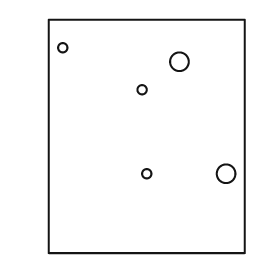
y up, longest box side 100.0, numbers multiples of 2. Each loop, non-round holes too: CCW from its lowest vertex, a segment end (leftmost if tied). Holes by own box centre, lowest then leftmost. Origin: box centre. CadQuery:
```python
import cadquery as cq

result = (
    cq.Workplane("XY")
    .moveTo(-42.0, -50.0)
    .lineTo(42.0, -50.0)
    .lineTo(42.0, 50.0)
    .lineTo(-42.0, 50.0)
    .close()
    .moveTo(0.0, -16.0)
    .circle(2.0)
    .moveTo(34.0, -16.0)
    .circle(4.0)
    .moveTo(-2.0, 20.0)
    .circle(2.0)
    .moveTo(14.0, 32.0)
    .circle(4.0)
    .moveTo(-36.0, 38.0)
    .circle(2.0)
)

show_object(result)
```